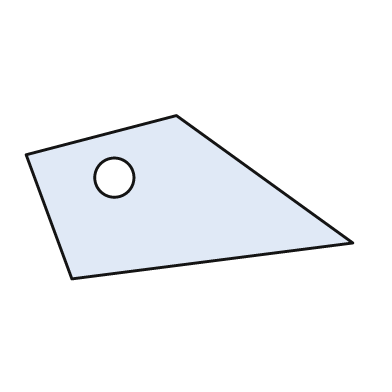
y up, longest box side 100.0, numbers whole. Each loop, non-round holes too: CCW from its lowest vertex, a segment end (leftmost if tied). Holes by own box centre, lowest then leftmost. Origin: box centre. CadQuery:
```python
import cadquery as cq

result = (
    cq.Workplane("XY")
    .moveTo(-36.0, -25.0)
    .lineTo(50.0, -14.0)
    .lineTo(-4.0, 25.0)
    .lineTo(-50.0, 13.0)
    .close()
    .moveTo(-23.0, 6.0)
    .circle(6.0)
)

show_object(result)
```